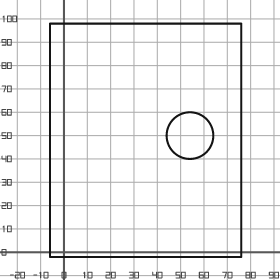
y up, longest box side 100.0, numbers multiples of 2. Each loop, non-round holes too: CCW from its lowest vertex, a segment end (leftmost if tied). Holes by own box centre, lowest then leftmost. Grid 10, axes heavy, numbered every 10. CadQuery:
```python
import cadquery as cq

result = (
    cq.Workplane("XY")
    .moveTo(-6.0, -2.0)
    .lineTo(76.0, -2.0)
    .lineTo(76.0, 98.0)
    .lineTo(-6.0, 98.0)
    .close()
    .moveTo(54.0, 50.0)
    .circle(10.0)
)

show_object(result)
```